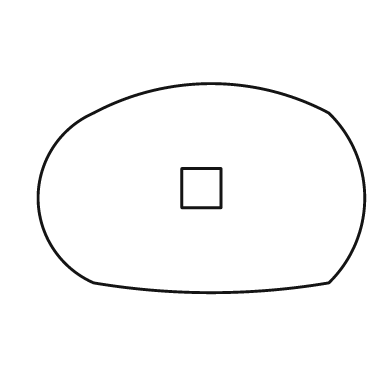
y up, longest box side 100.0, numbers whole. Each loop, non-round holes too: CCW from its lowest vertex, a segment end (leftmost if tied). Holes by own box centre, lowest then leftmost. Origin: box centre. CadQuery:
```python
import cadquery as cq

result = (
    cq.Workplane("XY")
    .moveTo(-33.0, -29.0)
    .threePointArc((3.0, -32.0), (39.0, -29.0))
    .threePointArc((50.0, -3.0), (39.0, 23.0))
    .threePointArc((3.0, 32.0), (-33.0, 23.0))
    .threePointArc((-50.0, -3.0), (-33.0, -29.0))
    .close()
    .moveTo(-6.0, -6.0)
    .lineTo(6.0, -6.0)
    .lineTo(6.0, 6.0)
    .lineTo(-6.0, 6.0)
    .close()
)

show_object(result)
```